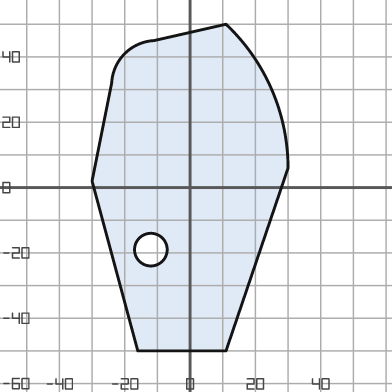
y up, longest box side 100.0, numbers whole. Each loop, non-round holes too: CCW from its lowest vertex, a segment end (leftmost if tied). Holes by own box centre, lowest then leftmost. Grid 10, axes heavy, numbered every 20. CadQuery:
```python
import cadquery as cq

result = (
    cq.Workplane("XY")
    .moveTo(-16.0, -50.0)
    .lineTo(11.0, -50.0)
    .lineTo(30.0, 6.0)
    .threePointArc((25.0, 30.0), (11.0, 50.0))
    .lineTo(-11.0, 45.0)
    .threePointArc((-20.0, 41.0), (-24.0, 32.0))
    .lineTo(-30.0, 2.0)
    .close()
    .moveTo(-12.0, -19.0)
    .circle(5.0)
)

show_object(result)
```